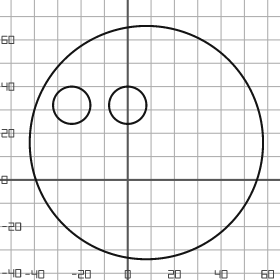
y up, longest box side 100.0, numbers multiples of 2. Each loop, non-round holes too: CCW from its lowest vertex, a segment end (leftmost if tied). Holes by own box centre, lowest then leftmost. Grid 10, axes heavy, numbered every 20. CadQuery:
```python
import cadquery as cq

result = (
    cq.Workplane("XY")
    .moveTo(8.0, 16.0)
    .circle(50.0)
    .moveTo(-24.0, 32.0)
    .circle(8.0)
    .moveTo(0.0, 32.0)
    .circle(8.0)
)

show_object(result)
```